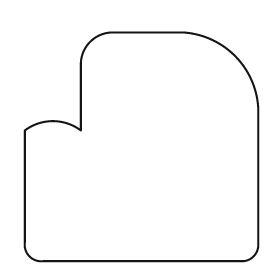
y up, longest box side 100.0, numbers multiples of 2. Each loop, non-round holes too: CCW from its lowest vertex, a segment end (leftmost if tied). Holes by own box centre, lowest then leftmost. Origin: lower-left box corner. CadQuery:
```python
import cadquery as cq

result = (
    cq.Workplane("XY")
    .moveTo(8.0, 0.0)
    .lineTo(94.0, 0.0)
    .threePointArc((98.0, 2.0), (100.0, 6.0))
    .lineTo(100.0, 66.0)
    .threePointArc((90.0, 88.0), (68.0, 98.0))
    .lineTo(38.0, 98.0)
    .threePointArc((28.0, 94.0), (24.0, 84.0))
    .lineTo(24.0, 56.0)
    .threePointArc((12.0, 60.0), (0.0, 56.0))
    .lineTo(0.0, 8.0)
    .threePointArc((2.0, 2.0), (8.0, 0.0))
    .close()
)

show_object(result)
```